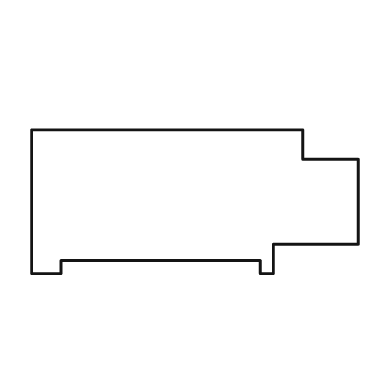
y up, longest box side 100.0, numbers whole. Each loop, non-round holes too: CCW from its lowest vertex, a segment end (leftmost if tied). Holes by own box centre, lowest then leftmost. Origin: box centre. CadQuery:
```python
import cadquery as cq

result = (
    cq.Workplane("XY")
    .moveTo(-50.0, -22.0)
    .lineTo(-41.0, -22.0)
    .lineTo(-41.0, -18.0)
    .lineTo(20.0, -18.0)
    .lineTo(20.0, -22.0)
    .lineTo(24.0, -22.0)
    .lineTo(24.0, -13.0)
    .lineTo(50.0, -13.0)
    .lineTo(50.0, 13.0)
    .lineTo(33.0, 13.0)
    .lineTo(33.0, 22.0)
    .lineTo(-50.0, 22.0)
    .close()
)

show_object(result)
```